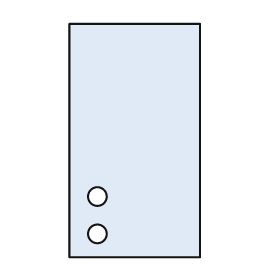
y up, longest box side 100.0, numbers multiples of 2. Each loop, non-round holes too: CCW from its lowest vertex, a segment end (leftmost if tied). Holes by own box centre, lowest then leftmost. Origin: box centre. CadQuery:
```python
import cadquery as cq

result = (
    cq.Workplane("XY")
    .moveTo(-28.0, -50.0)
    .lineTo(28.0, -50.0)
    .lineTo(28.0, 50.0)
    .lineTo(-28.0, 50.0)
    .close()
    .moveTo(-16.0, -40.0)
    .circle(4.0)
    .moveTo(-16.0, -24.0)
    .circle(4.0)
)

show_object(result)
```